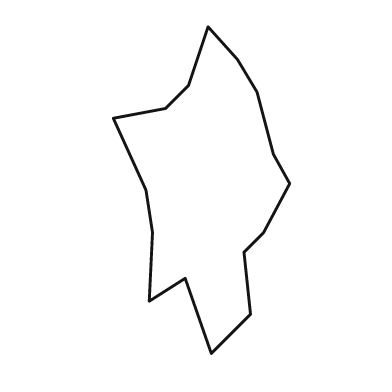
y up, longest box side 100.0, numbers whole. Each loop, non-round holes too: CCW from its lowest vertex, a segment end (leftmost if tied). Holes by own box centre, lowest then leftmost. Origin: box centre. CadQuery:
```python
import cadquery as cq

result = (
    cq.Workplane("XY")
    .moveTo(3.0, -50.0)
    .lineTo(15.0, -38.0)
    .lineTo(13.0, -19.0)
    .lineTo(19.0, -13.0)
    .lineTo(27.0, 2.0)
    .lineTo(22.0, 11.0)
    .lineTo(17.0, 30.0)
    .lineTo(11.0, 40.0)
    .lineTo(2.0, 50.0)
    .lineTo(-4.0, 32.0)
    .lineTo(-11.0, 25.0)
    .lineTo(-27.0, 22.0)
    .lineTo(-17.0, 0.0)
    .lineTo(-15.0, -13.0)
    .lineTo(-16.0, -34.0)
    .lineTo(-5.0, -27.0)
    .close()
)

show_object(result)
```